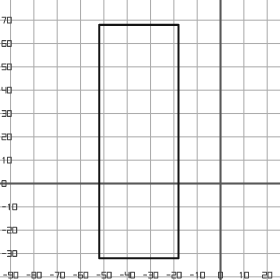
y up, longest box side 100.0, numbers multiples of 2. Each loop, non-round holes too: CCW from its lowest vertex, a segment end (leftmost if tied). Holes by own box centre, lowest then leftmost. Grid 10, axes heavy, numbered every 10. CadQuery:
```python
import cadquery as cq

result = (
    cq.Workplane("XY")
    .moveTo(-52.0, -32.0)
    .lineTo(-18.0, -32.0)
    .lineTo(-18.0, 68.0)
    .lineTo(-52.0, 68.0)
    .close()
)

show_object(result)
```